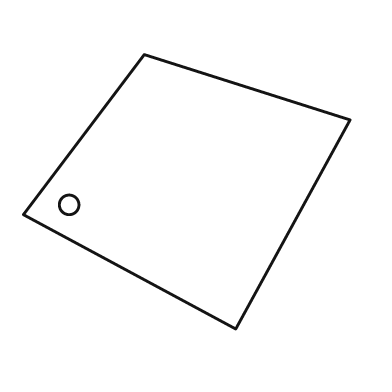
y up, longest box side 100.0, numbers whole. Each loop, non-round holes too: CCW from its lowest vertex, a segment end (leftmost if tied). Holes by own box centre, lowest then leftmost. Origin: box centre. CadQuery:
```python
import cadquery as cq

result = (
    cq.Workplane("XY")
    .moveTo(15.0, -42.0)
    .lineTo(50.0, 22.0)
    .lineTo(-13.0, 42.0)
    .lineTo(-50.0, -7.0)
    .close()
    .moveTo(-36.0, -4.0)
    .circle(3.0)
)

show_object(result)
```